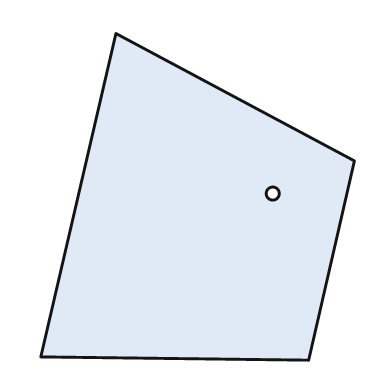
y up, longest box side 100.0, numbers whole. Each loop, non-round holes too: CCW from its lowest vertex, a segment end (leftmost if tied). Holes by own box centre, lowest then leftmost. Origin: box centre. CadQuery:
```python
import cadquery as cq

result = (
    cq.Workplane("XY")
    .moveTo(34.0, -50.0)
    .lineTo(48.0, 11.0)
    .lineTo(-25.0, 50.0)
    .lineTo(-48.0, -49.0)
    .close()
    .moveTo(23.0, 1.0)
    .circle(2.0)
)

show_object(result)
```